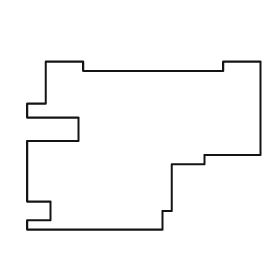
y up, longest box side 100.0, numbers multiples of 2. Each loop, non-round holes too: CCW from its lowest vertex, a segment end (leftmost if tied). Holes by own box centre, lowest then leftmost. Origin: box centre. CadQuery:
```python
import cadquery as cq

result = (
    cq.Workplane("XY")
    .moveTo(-50.0, -36.0)
    .lineTo(8.0, -36.0)
    .lineTo(8.0, -28.0)
    .lineTo(12.0, -28.0)
    .lineTo(12.0, -8.0)
    .lineTo(26.0, -8.0)
    .lineTo(26.0, -4.0)
    .lineTo(50.0, -4.0)
    .lineTo(50.0, 36.0)
    .lineTo(34.0, 36.0)
    .lineTo(34.0, 32.0)
    .lineTo(-26.0, 32.0)
    .lineTo(-26.0, 36.0)
    .lineTo(-42.0, 36.0)
    .lineTo(-42.0, 18.0)
    .lineTo(-50.0, 18.0)
    .lineTo(-50.0, 12.0)
    .lineTo(-28.0, 12.0)
    .lineTo(-28.0, 2.0)
    .lineTo(-50.0, 2.0)
    .lineTo(-50.0, -24.0)
    .lineTo(-40.0, -24.0)
    .lineTo(-40.0, -32.0)
    .lineTo(-50.0, -32.0)
    .close()
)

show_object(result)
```